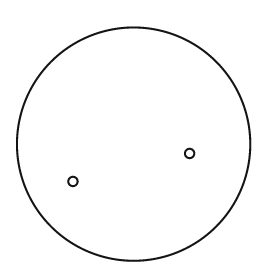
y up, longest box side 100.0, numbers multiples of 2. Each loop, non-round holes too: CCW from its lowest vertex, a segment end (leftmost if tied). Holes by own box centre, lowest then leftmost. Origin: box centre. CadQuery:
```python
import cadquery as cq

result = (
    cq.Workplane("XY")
    .moveTo(0.0, 0.0)
    .circle(50.0)
    .moveTo(-26.0, -16.0)
    .circle(2.0)
    .moveTo(24.0, -4.0)
    .circle(2.0)
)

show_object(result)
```